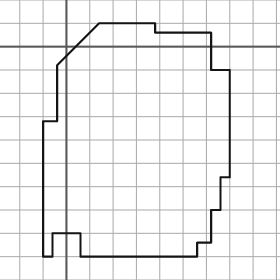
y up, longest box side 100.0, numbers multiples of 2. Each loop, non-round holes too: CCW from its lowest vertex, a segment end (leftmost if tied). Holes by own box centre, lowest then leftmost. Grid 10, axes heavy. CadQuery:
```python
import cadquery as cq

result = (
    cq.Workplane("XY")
    .moveTo(-10.0, -90.0)
    .lineTo(-6.0, -90.0)
    .lineTo(-6.0, -80.0)
    .lineTo(6.0, -80.0)
    .lineTo(6.0, -90.0)
    .lineTo(56.0, -90.0)
    .lineTo(56.0, -84.0)
    .lineTo(62.0, -84.0)
    .lineTo(62.0, -70.0)
    .lineTo(66.0, -70.0)
    .lineTo(66.0, -56.0)
    .lineTo(70.0, -56.0)
    .lineTo(70.0, -10.0)
    .lineTo(62.0, -10.0)
    .lineTo(62.0, 6.0)
    .lineTo(38.0, 6.0)
    .lineTo(38.0, 10.0)
    .lineTo(14.0, 10.0)
    .lineTo(-4.0, -8.0)
    .lineTo(-4.0, -32.0)
    .lineTo(-10.0, -32.0)
    .close()
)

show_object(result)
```